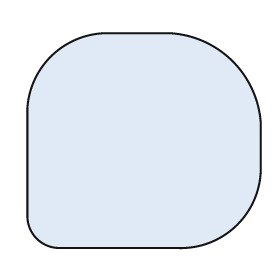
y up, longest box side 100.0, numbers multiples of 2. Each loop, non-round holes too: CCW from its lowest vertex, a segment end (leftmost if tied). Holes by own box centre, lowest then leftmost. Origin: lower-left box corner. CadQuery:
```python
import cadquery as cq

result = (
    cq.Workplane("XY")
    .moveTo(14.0, 0.0)
    .lineTo(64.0, 0.0)
    .threePointArc((90.0, 10.0), (100.0, 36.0))
    .lineTo(100.0, 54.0)
    .threePointArc((88.0, 80.0), (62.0, 92.0))
    .lineTo(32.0, 92.0)
    .threePointArc((10.0, 82.0), (0.0, 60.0))
    .lineTo(0.0, 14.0)
    .threePointArc((4.0, 4.0), (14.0, 0.0))
    .close()
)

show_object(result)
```